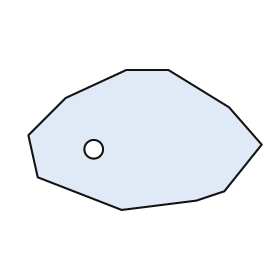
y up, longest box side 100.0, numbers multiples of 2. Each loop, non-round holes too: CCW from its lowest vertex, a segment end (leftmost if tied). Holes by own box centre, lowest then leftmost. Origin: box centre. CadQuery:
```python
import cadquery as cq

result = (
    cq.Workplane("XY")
    .moveTo(-10.0, -30.0)
    .lineTo(22.0, -26.0)
    .lineTo(34.0, -22.0)
    .lineTo(50.0, -2.0)
    .lineTo(36.0, 14.0)
    .lineTo(10.0, 30.0)
    .lineTo(-8.0, 30.0)
    .lineTo(-34.0, 18.0)
    .lineTo(-50.0, 2.0)
    .lineTo(-46.0, -16.0)
    .close()
    .moveTo(-22.0, -4.0)
    .circle(4.0)
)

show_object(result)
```